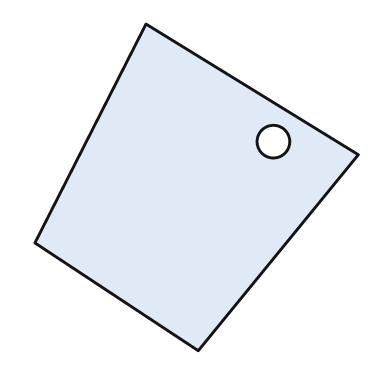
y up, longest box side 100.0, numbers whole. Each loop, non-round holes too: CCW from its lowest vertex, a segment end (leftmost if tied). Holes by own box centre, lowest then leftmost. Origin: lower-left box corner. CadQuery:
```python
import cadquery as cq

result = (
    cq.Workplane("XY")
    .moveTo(50.0, 0.0)
    .lineTo(99.0, 60.0)
    .lineTo(34.0, 100.0)
    .lineTo(0.0, 33.0)
    .close()
    .moveTo(73.0, 64.0)
    .circle(5.0)
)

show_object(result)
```